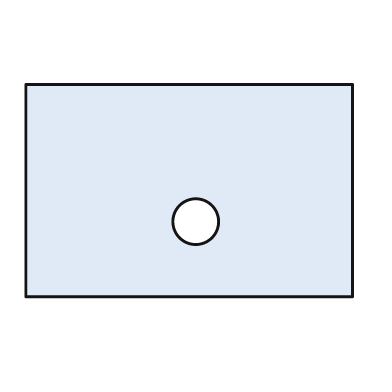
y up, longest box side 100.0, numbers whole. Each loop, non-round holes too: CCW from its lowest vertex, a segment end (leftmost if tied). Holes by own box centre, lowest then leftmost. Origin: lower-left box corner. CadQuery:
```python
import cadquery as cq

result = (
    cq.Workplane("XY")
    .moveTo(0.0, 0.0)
    .lineTo(100.0, 0.0)
    .lineTo(100.0, 65.0)
    .lineTo(0.0, 65.0)
    .close()
    .moveTo(52.0, 23.0)
    .circle(7.0)
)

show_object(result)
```